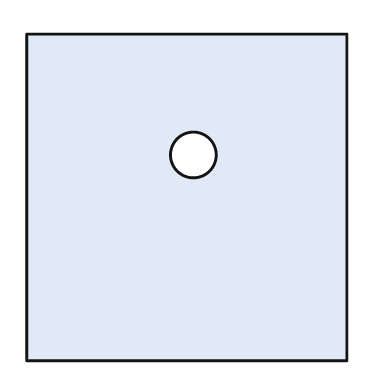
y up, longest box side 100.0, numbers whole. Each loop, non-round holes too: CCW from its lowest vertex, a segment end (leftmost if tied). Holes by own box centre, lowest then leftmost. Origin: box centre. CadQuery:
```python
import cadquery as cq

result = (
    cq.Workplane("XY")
    .moveTo(-49.0, -50.0)
    .lineTo(49.0, -50.0)
    .lineTo(49.0, 50.0)
    .lineTo(-49.0, 50.0)
    .close()
    .moveTo(2.0, 13.0)
    .circle(7.0)
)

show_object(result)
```